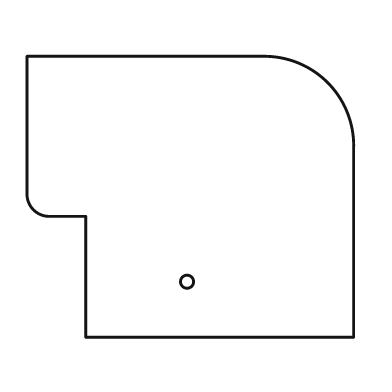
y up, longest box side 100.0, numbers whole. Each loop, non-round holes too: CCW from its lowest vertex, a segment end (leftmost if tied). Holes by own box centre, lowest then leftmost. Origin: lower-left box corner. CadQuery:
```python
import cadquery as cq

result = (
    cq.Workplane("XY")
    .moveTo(18.0, 0.0)
    .lineTo(100.0, 0.0)
    .lineTo(100.0, 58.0)
    .threePointArc((92.0, 78.0), (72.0, 86.0))
    .lineTo(0.0, 86.0)
    .lineTo(0.0, 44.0)
    .threePointArc((2.0, 39.0), (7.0, 37.0))
    .lineTo(18.0, 37.0)
    .close()
    .moveTo(49.0, 17.0)
    .circle(2.0)
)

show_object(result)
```